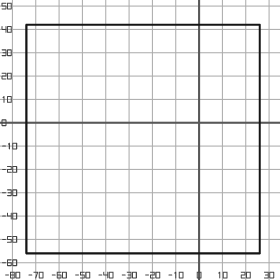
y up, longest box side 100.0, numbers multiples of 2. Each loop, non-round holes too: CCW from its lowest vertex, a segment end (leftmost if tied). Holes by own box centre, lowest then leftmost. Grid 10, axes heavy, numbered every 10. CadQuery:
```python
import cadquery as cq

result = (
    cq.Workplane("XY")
    .moveTo(-74.0, -56.0)
    .lineTo(26.0, -56.0)
    .lineTo(26.0, 42.0)
    .lineTo(-74.0, 42.0)
    .close()
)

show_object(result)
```